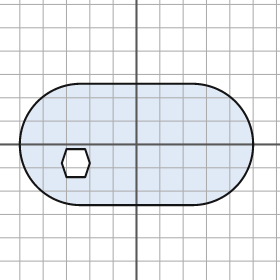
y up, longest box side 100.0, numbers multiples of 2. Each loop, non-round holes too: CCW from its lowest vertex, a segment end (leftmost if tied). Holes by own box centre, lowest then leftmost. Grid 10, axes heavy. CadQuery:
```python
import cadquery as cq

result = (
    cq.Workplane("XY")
    .moveTo(-24.0, -26.0)
    .lineTo(24.0, -26.0)
    .threePointArc((50.0, 0.0), (24.0, 26.0))
    .lineTo(-24.0, 26.0)
    .threePointArc((-50.0, 0.0), (-24.0, -26.0))
    .close()
    .moveTo(-30.0, -14.0)
    .lineTo(-22.0, -14.0)
    .lineTo(-20.0, -8.0)
    .lineTo(-22.0, -2.0)
    .lineTo(-30.0, -2.0)
    .lineTo(-32.0, -8.0)
    .close()
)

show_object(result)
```